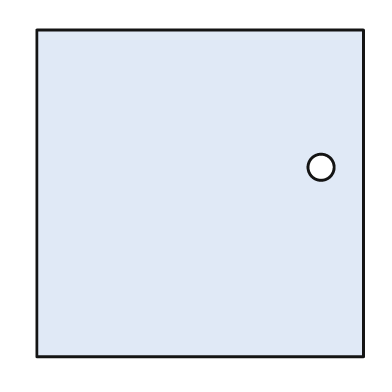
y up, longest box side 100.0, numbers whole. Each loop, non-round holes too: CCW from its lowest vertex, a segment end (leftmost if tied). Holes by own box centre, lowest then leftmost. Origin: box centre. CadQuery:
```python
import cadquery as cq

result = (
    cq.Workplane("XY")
    .moveTo(-50.0, -50.0)
    .lineTo(50.0, -50.0)
    .lineTo(50.0, 50.0)
    .lineTo(-50.0, 50.0)
    .close()
    .moveTo(37.0, 8.0)
    .circle(4.0)
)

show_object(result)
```